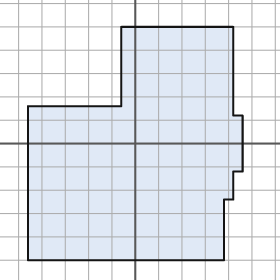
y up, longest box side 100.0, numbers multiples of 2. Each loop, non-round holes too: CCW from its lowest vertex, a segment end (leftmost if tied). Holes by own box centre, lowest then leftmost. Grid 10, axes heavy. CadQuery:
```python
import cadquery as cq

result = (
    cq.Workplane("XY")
    .moveTo(-46.0, -50.0)
    .lineTo(38.0, -50.0)
    .lineTo(38.0, -24.0)
    .lineTo(42.0, -24.0)
    .lineTo(42.0, -12.0)
    .lineTo(46.0, -12.0)
    .lineTo(46.0, 12.0)
    .lineTo(42.0, 12.0)
    .lineTo(42.0, 50.0)
    .lineTo(-6.0, 50.0)
    .lineTo(-6.0, 16.0)
    .lineTo(-46.0, 16.0)
    .close()
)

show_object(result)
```